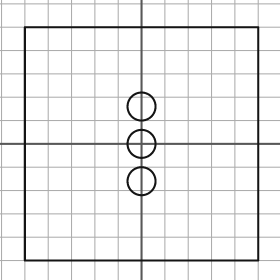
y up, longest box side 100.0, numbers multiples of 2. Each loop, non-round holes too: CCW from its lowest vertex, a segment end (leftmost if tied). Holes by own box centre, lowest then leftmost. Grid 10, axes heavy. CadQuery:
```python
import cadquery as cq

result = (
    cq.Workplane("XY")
    .moveTo(-50.0, -50.0)
    .lineTo(50.0, -50.0)
    .lineTo(50.0, 50.0)
    .lineTo(-50.0, 50.0)
    .close()
    .moveTo(0.0, -16.0)
    .circle(6.0)
    .moveTo(0.0, 0.0)
    .circle(6.0)
    .moveTo(0.0, 16.0)
    .circle(6.0)
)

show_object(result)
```